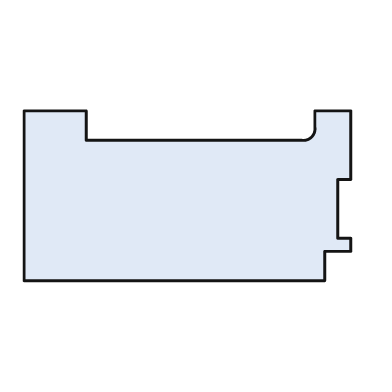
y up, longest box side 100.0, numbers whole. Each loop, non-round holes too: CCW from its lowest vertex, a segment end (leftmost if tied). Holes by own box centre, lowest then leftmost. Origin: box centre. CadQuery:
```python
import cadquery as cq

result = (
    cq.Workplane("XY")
    .moveTo(-50.0, -26.0)
    .lineTo(42.0, -26.0)
    .lineTo(42.0, -17.0)
    .lineTo(50.0, -17.0)
    .lineTo(50.0, -13.0)
    .lineTo(46.0, -13.0)
    .lineTo(46.0, 5.0)
    .lineTo(50.0, 5.0)
    .lineTo(50.0, 26.0)
    .lineTo(39.0, 26.0)
    .lineTo(39.0, 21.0)
    .threePointArc((38.0, 18.0), (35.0, 17.0))
    .lineTo(-31.0, 17.0)
    .lineTo(-31.0, 26.0)
    .lineTo(-50.0, 26.0)
    .close()
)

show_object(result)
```